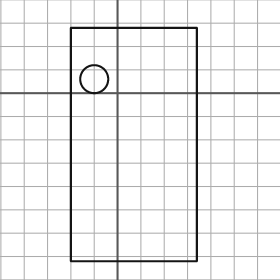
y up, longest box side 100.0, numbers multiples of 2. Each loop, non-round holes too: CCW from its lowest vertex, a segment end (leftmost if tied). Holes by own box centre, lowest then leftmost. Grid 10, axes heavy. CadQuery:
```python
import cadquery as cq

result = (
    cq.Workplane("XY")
    .moveTo(-20.0, -72.0)
    .lineTo(34.0, -72.0)
    .lineTo(34.0, 28.0)
    .lineTo(-20.0, 28.0)
    .close()
    .moveTo(-10.0, 6.0)
    .circle(6.0)
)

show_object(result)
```